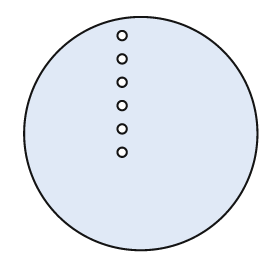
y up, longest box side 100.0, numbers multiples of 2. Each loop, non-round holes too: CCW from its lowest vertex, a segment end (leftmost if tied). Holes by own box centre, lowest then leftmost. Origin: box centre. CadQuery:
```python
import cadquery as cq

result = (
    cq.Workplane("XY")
    .moveTo(0.0, 0.0)
    .circle(50.0)
    .moveTo(-8.0, -8.0)
    .circle(2.0)
    .moveTo(-8.0, 2.0)
    .circle(2.0)
    .moveTo(-8.0, 12.0)
    .circle(2.0)
    .moveTo(-8.0, 22.0)
    .circle(2.0)
    .moveTo(-8.0, 32.0)
    .circle(2.0)
    .moveTo(-8.0, 42.0)
    .circle(2.0)
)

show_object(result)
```